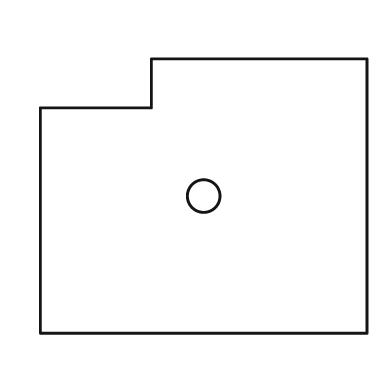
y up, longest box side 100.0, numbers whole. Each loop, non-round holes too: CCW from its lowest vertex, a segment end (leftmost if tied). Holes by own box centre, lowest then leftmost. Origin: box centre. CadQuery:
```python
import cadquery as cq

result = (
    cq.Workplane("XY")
    .moveTo(-50.0, -42.0)
    .lineTo(50.0, -42.0)
    .lineTo(50.0, 42.0)
    .lineTo(-16.0, 42.0)
    .lineTo(-16.0, 27.0)
    .lineTo(-50.0, 27.0)
    .close()
    .moveTo(0.0, 0.0)
    .circle(5.0)
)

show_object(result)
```